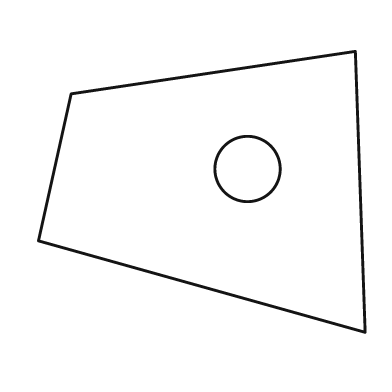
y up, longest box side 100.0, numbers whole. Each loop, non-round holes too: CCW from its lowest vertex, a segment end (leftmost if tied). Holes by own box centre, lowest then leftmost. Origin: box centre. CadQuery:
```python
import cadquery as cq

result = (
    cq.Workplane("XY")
    .moveTo(50.0, -43.0)
    .lineTo(47.0, 43.0)
    .lineTo(-40.0, 30.0)
    .lineTo(-50.0, -15.0)
    .close()
    .moveTo(14.0, 7.0)
    .circle(10.0)
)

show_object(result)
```